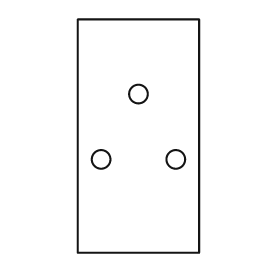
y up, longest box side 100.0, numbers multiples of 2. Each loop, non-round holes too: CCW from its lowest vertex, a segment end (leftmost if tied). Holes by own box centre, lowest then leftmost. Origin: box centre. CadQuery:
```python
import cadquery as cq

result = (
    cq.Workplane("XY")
    .moveTo(-26.0, -50.0)
    .lineTo(26.0, -50.0)
    .lineTo(26.0, 50.0)
    .lineTo(-26.0, 50.0)
    .close()
    .moveTo(-16.0, -10.0)
    .circle(4.0)
    .moveTo(16.0, -10.0)
    .circle(4.0)
    .moveTo(0.0, 18.0)
    .circle(4.0)
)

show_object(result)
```